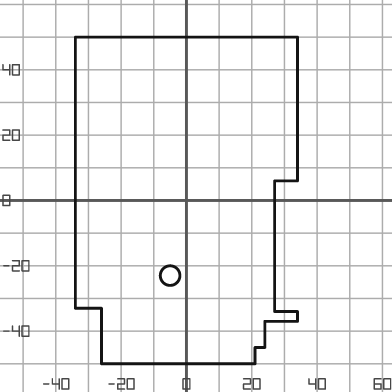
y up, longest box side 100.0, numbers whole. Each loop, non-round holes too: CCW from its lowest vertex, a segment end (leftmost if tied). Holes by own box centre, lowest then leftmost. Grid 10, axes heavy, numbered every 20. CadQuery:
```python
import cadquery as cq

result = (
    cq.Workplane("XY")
    .moveTo(-26.0, -50.0)
    .lineTo(21.0, -50.0)
    .lineTo(21.0, -45.0)
    .lineTo(24.0, -45.0)
    .lineTo(24.0, -37.0)
    .lineTo(34.0, -37.0)
    .lineTo(34.0, -34.0)
    .lineTo(27.0, -34.0)
    .lineTo(27.0, 6.0)
    .lineTo(34.0, 6.0)
    .lineTo(34.0, 50.0)
    .lineTo(-34.0, 50.0)
    .lineTo(-34.0, -33.0)
    .lineTo(-26.0, -33.0)
    .close()
    .moveTo(-5.0, -23.0)
    .circle(3.0)
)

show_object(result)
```